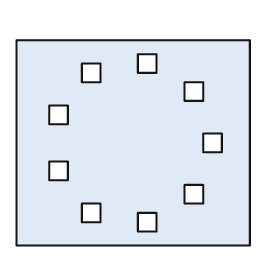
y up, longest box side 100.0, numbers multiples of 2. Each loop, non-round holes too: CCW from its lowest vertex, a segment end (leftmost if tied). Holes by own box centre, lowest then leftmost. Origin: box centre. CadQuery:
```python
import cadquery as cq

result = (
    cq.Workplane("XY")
    .moveTo(-50.0, -44.0)
    .lineTo(50.0, -44.0)
    .lineTo(50.0, 44.0)
    .lineTo(-50.0, 44.0)
    .close()
    .moveTo(2.0, -38.0)
    .lineTo(10.0, -38.0)
    .lineTo(10.0, -30.0)
    .lineTo(2.0, -30.0)
    .close()
    .moveTo(-22.0, -34.0)
    .lineTo(-14.0, -34.0)
    .lineTo(-14.0, -26.0)
    .lineTo(-22.0, -26.0)
    .close()
    .moveTo(22.0, -26.0)
    .lineTo(30.0, -26.0)
    .lineTo(30.0, -18.0)
    .lineTo(22.0, -18.0)
    .close()
    .moveTo(-36.0, -16.0)
    .lineTo(-28.0, -16.0)
    .lineTo(-28.0, -8.0)
    .lineTo(-36.0, -8.0)
    .close()
    .moveTo(30.0, -4.0)
    .lineTo(38.0, -4.0)
    .lineTo(38.0, 4.0)
    .lineTo(30.0, 4.0)
    .close()
    .moveTo(-36.0, 8.0)
    .lineTo(-28.0, 8.0)
    .lineTo(-28.0, 16.0)
    .lineTo(-36.0, 16.0)
    .close()
    .moveTo(22.0, 18.0)
    .lineTo(30.0, 18.0)
    .lineTo(30.0, 26.0)
    .lineTo(22.0, 26.0)
    .close()
    .moveTo(-22.0, 26.0)
    .lineTo(-14.0, 26.0)
    .lineTo(-14.0, 34.0)
    .lineTo(-22.0, 34.0)
    .close()
    .moveTo(2.0, 30.0)
    .lineTo(10.0, 30.0)
    .lineTo(10.0, 38.0)
    .lineTo(2.0, 38.0)
    .close()
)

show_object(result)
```